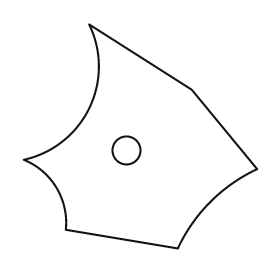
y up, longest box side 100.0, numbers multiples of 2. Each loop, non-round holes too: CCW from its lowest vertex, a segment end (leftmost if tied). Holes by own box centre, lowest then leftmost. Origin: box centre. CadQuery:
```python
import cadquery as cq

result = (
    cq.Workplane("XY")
    .moveTo(16.0, -48.0)
    .threePointArc((30.0, -28.0), (50.0, -14.0))
    .lineTo(22.0, 20.0)
    .lineTo(-22.0, 48.0)
    .threePointArc((-22.0, 12.0), (-50.0, -10.0))
    .threePointArc((-36.0, -22.0), (-32.0, -40.0))
    .close()
    .moveTo(-6.0, -6.0)
    .circle(6.0)
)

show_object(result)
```